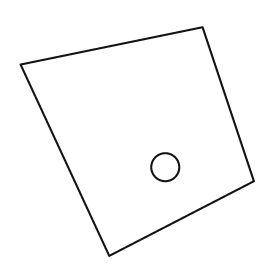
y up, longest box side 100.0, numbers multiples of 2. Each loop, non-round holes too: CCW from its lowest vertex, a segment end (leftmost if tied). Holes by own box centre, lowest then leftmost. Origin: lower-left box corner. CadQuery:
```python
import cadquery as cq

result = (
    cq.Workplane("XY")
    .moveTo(38.0, 0.0)
    .lineTo(100.0, 32.0)
    .lineTo(78.0, 98.0)
    .lineTo(0.0, 82.0)
    .close()
    .moveTo(62.0, 38.0)
    .circle(6.0)
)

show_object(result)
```